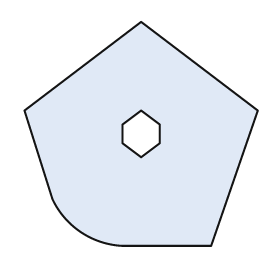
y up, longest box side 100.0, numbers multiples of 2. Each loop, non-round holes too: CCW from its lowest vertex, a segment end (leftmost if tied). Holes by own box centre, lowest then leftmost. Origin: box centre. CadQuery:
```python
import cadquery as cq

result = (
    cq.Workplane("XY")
    .moveTo(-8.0, -48.0)
    .lineTo(30.0, -48.0)
    .lineTo(50.0, 10.0)
    .lineTo(0.0, 48.0)
    .lineTo(-50.0, 10.0)
    .lineTo(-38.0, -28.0)
    .threePointArc((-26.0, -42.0), (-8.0, -48.0))
    .close()
    .moveTo(0.0, -10.0)
    .lineTo(8.0, -4.0)
    .lineTo(8.0, 4.0)
    .lineTo(0.0, 10.0)
    .lineTo(-8.0, 4.0)
    .lineTo(-8.0, -4.0)
    .close()
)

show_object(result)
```